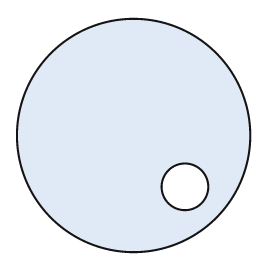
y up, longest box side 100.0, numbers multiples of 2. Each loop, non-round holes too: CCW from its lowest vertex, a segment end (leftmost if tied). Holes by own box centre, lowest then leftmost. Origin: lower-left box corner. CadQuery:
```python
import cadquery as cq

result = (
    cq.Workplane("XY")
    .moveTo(50.0, 50.0)
    .circle(50.0)
    .moveTo(72.0, 28.0)
    .circle(10.0)
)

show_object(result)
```